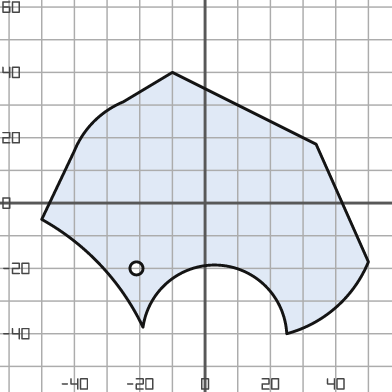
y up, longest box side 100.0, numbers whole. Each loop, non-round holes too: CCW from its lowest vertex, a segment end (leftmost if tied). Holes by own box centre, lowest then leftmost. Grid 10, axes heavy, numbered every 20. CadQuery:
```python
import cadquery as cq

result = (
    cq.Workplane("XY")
    .moveTo(25.0, -40.0)
    .threePointArc((40.0, -32.0), (50.0, -18.0))
    .lineTo(34.0, 18.0)
    .lineTo(-10.0, 40.0)
    .lineTo(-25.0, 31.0)
    .threePointArc((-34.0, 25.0), (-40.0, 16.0))
    .lineTo(-50.0, -5.0)
    .threePointArc((-32.0, -19.0), (-19.0, -38.0))
    .threePointArc((4.0, -19.0), (25.0, -40.0))
    .close()
    .moveTo(-21.0, -20.0)
    .circle(2.0)
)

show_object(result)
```